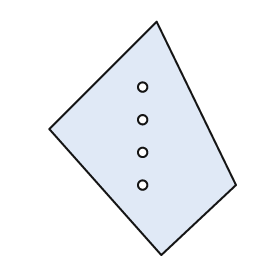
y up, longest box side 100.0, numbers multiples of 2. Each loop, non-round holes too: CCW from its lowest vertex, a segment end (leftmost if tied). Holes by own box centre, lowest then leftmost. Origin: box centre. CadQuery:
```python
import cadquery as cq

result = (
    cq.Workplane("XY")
    .moveTo(8.0, -50.0)
    .lineTo(40.0, -20.0)
    .lineTo(6.0, 50.0)
    .lineTo(-40.0, 4.0)
    .close()
    .moveTo(0.0, -20.0)
    .circle(2.0)
    .moveTo(0.0, -6.0)
    .circle(2.0)
    .moveTo(0.0, 8.0)
    .circle(2.0)
    .moveTo(0.0, 22.0)
    .circle(2.0)
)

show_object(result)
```